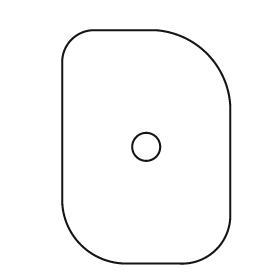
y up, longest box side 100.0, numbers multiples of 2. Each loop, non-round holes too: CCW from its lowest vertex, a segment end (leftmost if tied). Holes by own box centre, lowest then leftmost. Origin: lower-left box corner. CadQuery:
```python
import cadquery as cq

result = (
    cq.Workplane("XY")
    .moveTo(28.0, 0.0)
    .lineTo(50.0, 0.0)
    .threePointArc((66.0, 6.0), (72.0, 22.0))
    .lineTo(72.0, 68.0)
    .threePointArc((62.0, 90.0), (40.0, 100.0))
    .lineTo(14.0, 100.0)
    .threePointArc((4.0, 96.0), (0.0, 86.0))
    .lineTo(0.0, 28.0)
    .threePointArc((8.0, 8.0), (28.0, 0.0))
    .close()
    .moveTo(36.0, 50.0)
    .circle(6.0)
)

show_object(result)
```